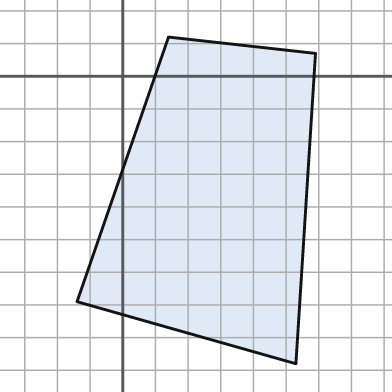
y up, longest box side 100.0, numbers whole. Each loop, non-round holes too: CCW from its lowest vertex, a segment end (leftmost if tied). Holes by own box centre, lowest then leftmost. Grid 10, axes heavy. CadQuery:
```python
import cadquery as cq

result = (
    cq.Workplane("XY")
    .moveTo(53.0, -88.0)
    .lineTo(59.0, 7.0)
    .lineTo(14.0, 12.0)
    .lineTo(-14.0, -69.0)
    .close()
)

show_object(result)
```